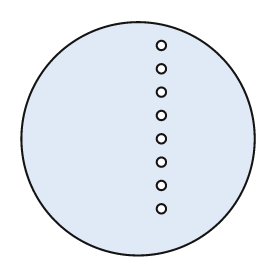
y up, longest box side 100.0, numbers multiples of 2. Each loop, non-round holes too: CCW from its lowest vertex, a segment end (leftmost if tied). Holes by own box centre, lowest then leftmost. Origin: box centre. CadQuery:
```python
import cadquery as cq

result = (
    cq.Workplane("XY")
    .moveTo(0.0, 0.0)
    .circle(50.0)
    .moveTo(10.0, -30.0)
    .circle(2.0)
    .moveTo(10.0, -20.0)
    .circle(2.0)
    .moveTo(10.0, -10.0)
    .circle(2.0)
    .moveTo(10.0, 0.0)
    .circle(2.0)
    .moveTo(10.0, 10.0)
    .circle(2.0)
    .moveTo(10.0, 20.0)
    .circle(2.0)
    .moveTo(10.0, 30.0)
    .circle(2.0)
    .moveTo(10.0, 40.0)
    .circle(2.0)
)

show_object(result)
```